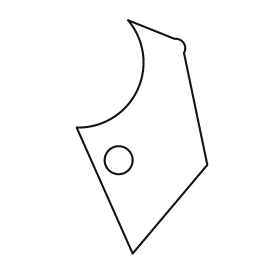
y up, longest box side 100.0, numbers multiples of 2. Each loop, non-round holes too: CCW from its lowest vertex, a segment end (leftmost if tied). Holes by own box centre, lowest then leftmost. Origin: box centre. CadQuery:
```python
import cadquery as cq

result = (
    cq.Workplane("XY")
    .moveTo(-4.0, -50.0)
    .lineTo(28.0, -12.0)
    .lineTo(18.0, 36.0)
    .threePointArc((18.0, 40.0), (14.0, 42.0))
    .lineTo(-6.0, 50.0)
    .threePointArc((-2.0, 20.0), (-28.0, 4.0))
    .close()
    .moveTo(-10.0, -10.0)
    .circle(6.0)
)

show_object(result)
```